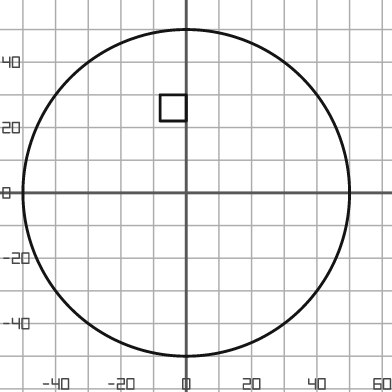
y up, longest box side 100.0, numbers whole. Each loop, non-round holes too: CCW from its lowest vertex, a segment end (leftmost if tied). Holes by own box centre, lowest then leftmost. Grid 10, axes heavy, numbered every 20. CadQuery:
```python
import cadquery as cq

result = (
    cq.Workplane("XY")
    .moveTo(0.0, 0.0)
    .circle(50.0)
    .moveTo(-8.0, 22.0)
    .lineTo(0.0, 22.0)
    .lineTo(0.0, 30.0)
    .lineTo(-8.0, 30.0)
    .close()
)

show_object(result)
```